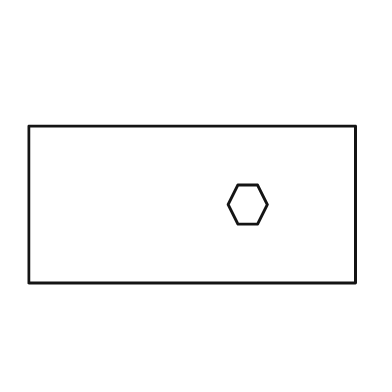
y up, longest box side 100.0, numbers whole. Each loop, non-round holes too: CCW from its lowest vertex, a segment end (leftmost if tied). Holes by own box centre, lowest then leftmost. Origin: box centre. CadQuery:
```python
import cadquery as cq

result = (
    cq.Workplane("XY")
    .moveTo(-50.0, -24.0)
    .lineTo(50.0, -24.0)
    .lineTo(50.0, 24.0)
    .lineTo(-50.0, 24.0)
    .close()
    .moveTo(14.0, -6.0)
    .lineTo(20.0, -6.0)
    .lineTo(23.0, 0.0)
    .lineTo(20.0, 6.0)
    .lineTo(14.0, 6.0)
    .lineTo(11.0, 0.0)
    .close()
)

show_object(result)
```